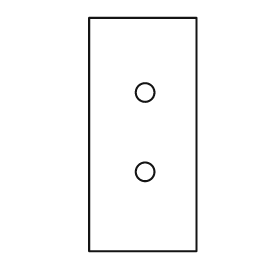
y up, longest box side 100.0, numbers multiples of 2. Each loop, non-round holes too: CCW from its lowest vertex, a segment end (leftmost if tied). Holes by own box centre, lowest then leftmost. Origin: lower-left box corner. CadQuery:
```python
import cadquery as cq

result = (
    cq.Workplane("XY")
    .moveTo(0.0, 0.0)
    .lineTo(46.0, 0.0)
    .lineTo(46.0, 100.0)
    .lineTo(0.0, 100.0)
    .close()
    .moveTo(24.0, 34.0)
    .circle(4.0)
    .moveTo(24.0, 68.0)
    .circle(4.0)
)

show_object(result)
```